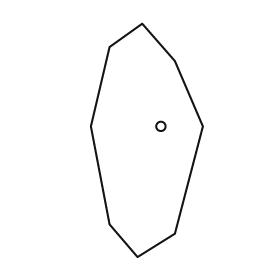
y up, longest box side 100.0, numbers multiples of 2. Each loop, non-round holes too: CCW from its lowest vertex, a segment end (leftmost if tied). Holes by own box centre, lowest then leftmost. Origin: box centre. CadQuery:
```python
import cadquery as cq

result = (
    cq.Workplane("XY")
    .moveTo(-4.0, -50.0)
    .lineTo(12.0, -40.0)
    .lineTo(24.0, 6.0)
    .lineTo(12.0, 34.0)
    .lineTo(-2.0, 50.0)
    .lineTo(-16.0, 40.0)
    .lineTo(-24.0, 6.0)
    .lineTo(-16.0, -36.0)
    .close()
    .moveTo(6.0, 6.0)
    .circle(2.0)
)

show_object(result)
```